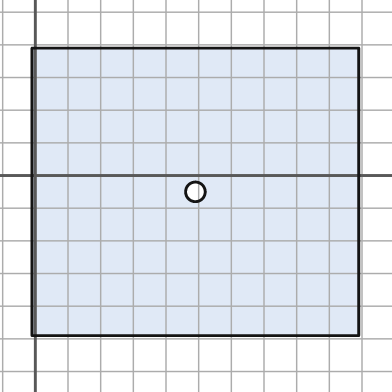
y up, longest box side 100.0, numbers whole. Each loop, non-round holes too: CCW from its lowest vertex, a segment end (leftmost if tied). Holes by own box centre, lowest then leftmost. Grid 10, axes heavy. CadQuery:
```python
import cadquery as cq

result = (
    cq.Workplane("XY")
    .moveTo(-1.0, -49.0)
    .lineTo(99.0, -49.0)
    .lineTo(99.0, 39.0)
    .lineTo(-1.0, 39.0)
    .close()
    .moveTo(49.0, -5.0)
    .circle(3.0)
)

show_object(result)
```